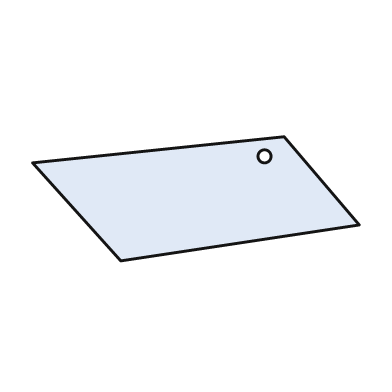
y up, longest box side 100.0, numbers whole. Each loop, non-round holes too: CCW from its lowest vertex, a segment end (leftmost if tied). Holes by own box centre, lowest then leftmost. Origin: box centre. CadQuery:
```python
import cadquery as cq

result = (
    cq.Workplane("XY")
    .moveTo(-23.0, -19.0)
    .lineTo(50.0, -8.0)
    .lineTo(27.0, 19.0)
    .lineTo(-50.0, 11.0)
    .close()
    .moveTo(21.0, 13.0)
    .circle(2.0)
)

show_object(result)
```